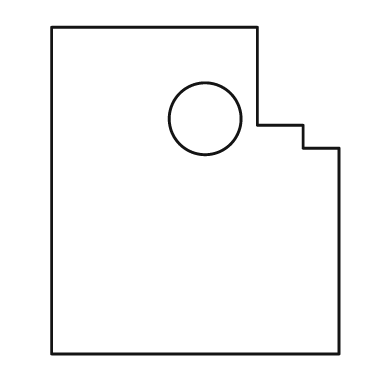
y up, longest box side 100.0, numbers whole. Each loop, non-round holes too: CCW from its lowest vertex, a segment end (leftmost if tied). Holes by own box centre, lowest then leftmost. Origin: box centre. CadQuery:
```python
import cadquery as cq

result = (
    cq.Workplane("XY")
    .moveTo(-44.0, -50.0)
    .lineTo(44.0, -50.0)
    .lineTo(44.0, 13.0)
    .lineTo(33.0, 13.0)
    .lineTo(33.0, 20.0)
    .lineTo(19.0, 20.0)
    .lineTo(19.0, 50.0)
    .lineTo(-44.0, 50.0)
    .close()
    .moveTo(3.0, 22.0)
    .circle(11.0)
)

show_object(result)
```